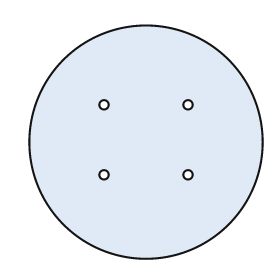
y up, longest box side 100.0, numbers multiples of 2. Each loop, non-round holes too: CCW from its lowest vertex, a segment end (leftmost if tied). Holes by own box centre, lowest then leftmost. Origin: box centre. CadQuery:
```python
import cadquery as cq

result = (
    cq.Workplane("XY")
    .moveTo(0.0, 0.0)
    .circle(50.0)
    .moveTo(-18.0, -14.0)
    .circle(2.0)
    .moveTo(18.0, -14.0)
    .circle(2.0)
    .moveTo(-18.0, 16.0)
    .circle(2.0)
    .moveTo(18.0, 16.0)
    .circle(2.0)
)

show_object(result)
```